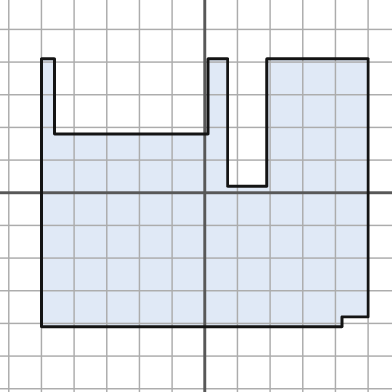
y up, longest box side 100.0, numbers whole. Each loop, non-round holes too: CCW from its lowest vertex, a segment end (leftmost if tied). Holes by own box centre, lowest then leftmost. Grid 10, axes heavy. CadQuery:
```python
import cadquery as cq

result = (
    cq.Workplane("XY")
    .moveTo(-50.0, -41.0)
    .lineTo(42.0, -41.0)
    .lineTo(42.0, -38.0)
    .lineTo(50.0, -38.0)
    .lineTo(50.0, 41.0)
    .lineTo(19.0, 41.0)
    .lineTo(19.0, 2.0)
    .lineTo(7.0, 2.0)
    .lineTo(7.0, 41.0)
    .lineTo(1.0, 41.0)
    .lineTo(1.0, 18.0)
    .lineTo(-46.0, 18.0)
    .lineTo(-46.0, 41.0)
    .lineTo(-50.0, 41.0)
    .close()
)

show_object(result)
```